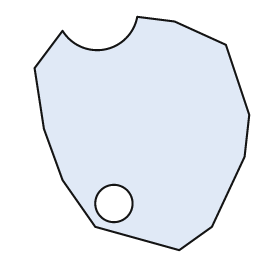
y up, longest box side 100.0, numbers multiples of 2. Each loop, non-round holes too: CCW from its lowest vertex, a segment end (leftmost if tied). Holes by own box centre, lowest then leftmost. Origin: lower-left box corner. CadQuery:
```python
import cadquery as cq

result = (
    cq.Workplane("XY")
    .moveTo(62.0, 0.0)
    .lineTo(76.0, 10.0)
    .lineTo(90.0, 40.0)
    .lineTo(92.0, 58.0)
    .lineTo(82.0, 88.0)
    .lineTo(60.0, 98.0)
    .lineTo(44.0, 100.0)
    .threePointArc((30.0, 86.0), (12.0, 94.0))
    .lineTo(0.0, 78.0)
    .lineTo(4.0, 52.0)
    .lineTo(12.0, 30.0)
    .lineTo(26.0, 10.0)
    .close()
    .moveTo(34.0, 20.0)
    .circle(8.0)
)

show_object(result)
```